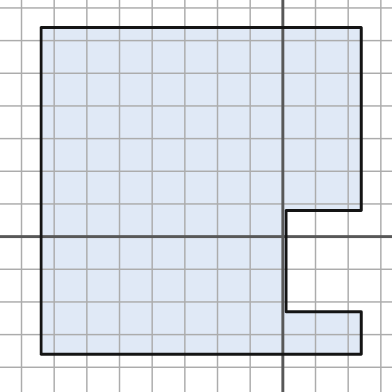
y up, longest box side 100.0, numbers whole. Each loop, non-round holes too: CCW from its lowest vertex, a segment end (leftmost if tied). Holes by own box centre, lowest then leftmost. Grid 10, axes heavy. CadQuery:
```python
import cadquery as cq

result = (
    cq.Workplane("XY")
    .moveTo(-74.0, -36.0)
    .lineTo(24.0, -36.0)
    .lineTo(24.0, -23.0)
    .lineTo(1.0, -23.0)
    .lineTo(1.0, 8.0)
    .lineTo(24.0, 8.0)
    .lineTo(24.0, 64.0)
    .lineTo(-74.0, 64.0)
    .close()
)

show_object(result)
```